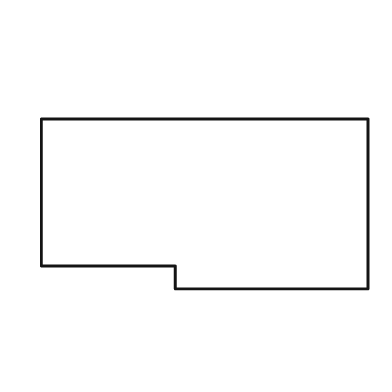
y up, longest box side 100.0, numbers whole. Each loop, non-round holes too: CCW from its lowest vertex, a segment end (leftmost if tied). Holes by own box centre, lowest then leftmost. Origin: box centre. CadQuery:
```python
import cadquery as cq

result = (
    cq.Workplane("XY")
    .moveTo(-9.0, -26.0)
    .lineTo(50.0, -26.0)
    .lineTo(50.0, 26.0)
    .lineTo(-50.0, 26.0)
    .lineTo(-50.0, -19.0)
    .lineTo(-9.0, -19.0)
    .close()
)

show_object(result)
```